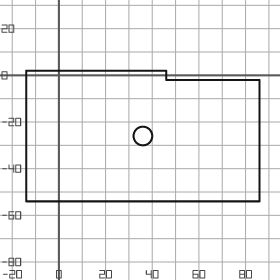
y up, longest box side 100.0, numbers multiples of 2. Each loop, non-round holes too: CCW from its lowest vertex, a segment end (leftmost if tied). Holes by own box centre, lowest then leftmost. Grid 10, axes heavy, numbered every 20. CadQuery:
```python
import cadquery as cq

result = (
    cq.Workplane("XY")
    .moveTo(-14.0, -54.0)
    .lineTo(86.0, -54.0)
    .lineTo(86.0, -2.0)
    .lineTo(46.0, -2.0)
    .lineTo(46.0, 2.0)
    .lineTo(-14.0, 2.0)
    .close()
    .moveTo(36.0, -26.0)
    .circle(4.0)
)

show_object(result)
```